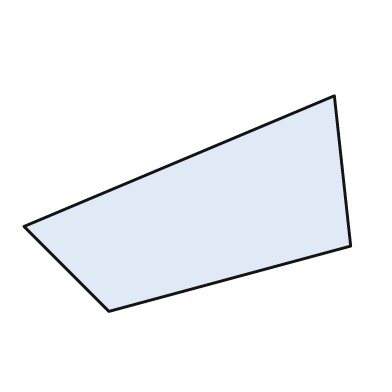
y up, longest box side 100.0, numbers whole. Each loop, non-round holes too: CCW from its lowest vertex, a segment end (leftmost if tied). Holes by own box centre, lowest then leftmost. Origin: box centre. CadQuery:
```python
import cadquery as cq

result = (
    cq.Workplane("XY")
    .moveTo(-24.0, -33.0)
    .lineTo(50.0, -13.0)
    .lineTo(45.0, 33.0)
    .lineTo(-50.0, -7.0)
    .close()
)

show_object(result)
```